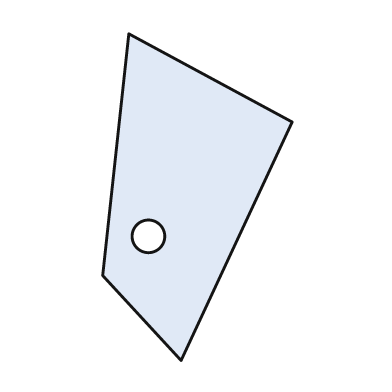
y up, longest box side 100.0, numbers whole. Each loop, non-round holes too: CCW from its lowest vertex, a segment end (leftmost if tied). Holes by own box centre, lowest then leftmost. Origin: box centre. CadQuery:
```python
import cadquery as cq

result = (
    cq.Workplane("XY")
    .moveTo(-5.0, -50.0)
    .lineTo(29.0, 23.0)
    .lineTo(-21.0, 50.0)
    .lineTo(-29.0, -24.0)
    .close()
    .moveTo(-15.0, -12.0)
    .circle(5.0)
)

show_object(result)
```